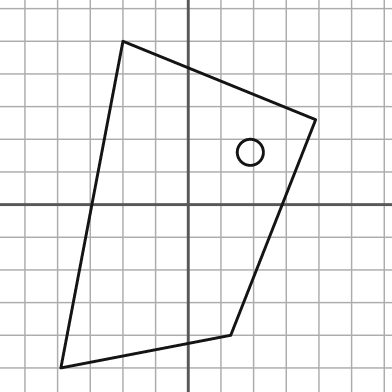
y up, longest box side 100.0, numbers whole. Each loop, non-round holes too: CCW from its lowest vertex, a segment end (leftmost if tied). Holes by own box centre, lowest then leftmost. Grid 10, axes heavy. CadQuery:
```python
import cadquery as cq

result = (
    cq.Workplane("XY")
    .moveTo(-39.0, -50.0)
    .lineTo(13.0, -40.0)
    .lineTo(39.0, 26.0)
    .lineTo(-20.0, 50.0)
    .close()
    .moveTo(19.0, 16.0)
    .circle(4.0)
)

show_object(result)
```